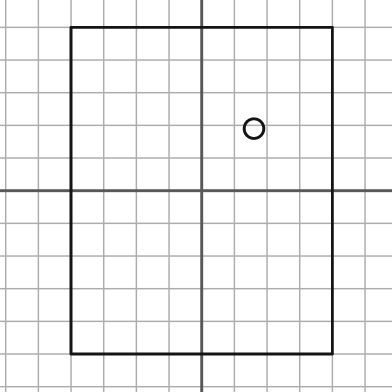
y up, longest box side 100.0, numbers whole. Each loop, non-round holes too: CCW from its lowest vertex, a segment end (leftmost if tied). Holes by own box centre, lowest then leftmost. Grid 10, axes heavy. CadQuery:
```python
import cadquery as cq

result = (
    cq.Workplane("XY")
    .moveTo(-40.0, -50.0)
    .lineTo(40.0, -50.0)
    .lineTo(40.0, 50.0)
    .lineTo(-40.0, 50.0)
    .close()
    .moveTo(16.0, 19.0)
    .circle(3.0)
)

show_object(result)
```